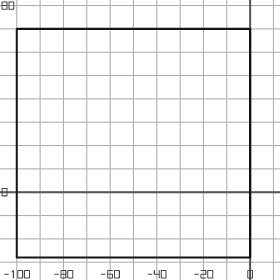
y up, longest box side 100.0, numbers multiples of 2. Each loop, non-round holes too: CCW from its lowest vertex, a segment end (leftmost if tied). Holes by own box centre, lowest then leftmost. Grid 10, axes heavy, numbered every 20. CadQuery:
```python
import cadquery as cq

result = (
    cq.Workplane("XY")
    .moveTo(-100.0, -28.0)
    .lineTo(0.0, -28.0)
    .lineTo(0.0, 70.0)
    .lineTo(-100.0, 70.0)
    .close()
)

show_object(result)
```